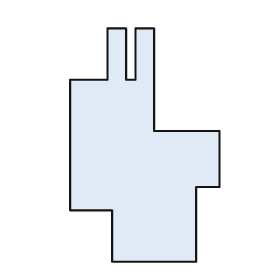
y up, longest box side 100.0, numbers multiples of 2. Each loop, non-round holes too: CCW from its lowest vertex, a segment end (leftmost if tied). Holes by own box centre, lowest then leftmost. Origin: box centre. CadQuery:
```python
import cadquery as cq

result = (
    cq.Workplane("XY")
    .moveTo(-14.0, -50.0)
    .lineTo(22.0, -50.0)
    .lineTo(22.0, -18.0)
    .lineTo(32.0, -18.0)
    .lineTo(32.0, 6.0)
    .lineTo(4.0, 6.0)
    .lineTo(4.0, 50.0)
    .lineTo(-4.0, 50.0)
    .lineTo(-4.0, 28.0)
    .lineTo(-8.0, 28.0)
    .lineTo(-8.0, 50.0)
    .lineTo(-16.0, 50.0)
    .lineTo(-16.0, 28.0)
    .lineTo(-32.0, 28.0)
    .lineTo(-32.0, -28.0)
    .lineTo(-14.0, -28.0)
    .close()
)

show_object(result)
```